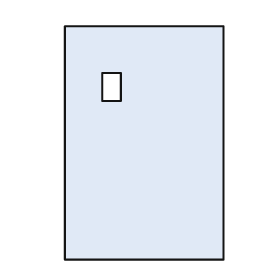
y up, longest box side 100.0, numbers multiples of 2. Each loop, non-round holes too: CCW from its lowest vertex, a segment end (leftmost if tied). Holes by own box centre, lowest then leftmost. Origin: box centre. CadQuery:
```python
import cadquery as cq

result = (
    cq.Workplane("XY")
    .moveTo(-34.0, -50.0)
    .lineTo(34.0, -50.0)
    .lineTo(34.0, 50.0)
    .lineTo(-34.0, 50.0)
    .close()
    .moveTo(-18.0, 18.0)
    .lineTo(-10.0, 18.0)
    .lineTo(-10.0, 30.0)
    .lineTo(-18.0, 30.0)
    .close()
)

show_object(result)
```